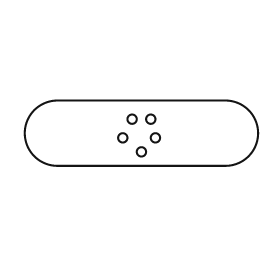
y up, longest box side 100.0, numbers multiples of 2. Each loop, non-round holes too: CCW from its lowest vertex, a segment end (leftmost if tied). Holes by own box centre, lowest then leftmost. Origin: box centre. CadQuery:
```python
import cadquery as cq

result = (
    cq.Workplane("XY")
    .moveTo(-36.0, -14.0)
    .lineTo(36.0, -14.0)
    .threePointArc((50.0, 0.0), (36.0, 14.0))
    .lineTo(-36.0, 14.0)
    .threePointArc((-50.0, 0.0), (-36.0, -14.0))
    .close()
    .moveTo(0.0, -8.0)
    .circle(2.0)
    .moveTo(-8.0, -2.0)
    .circle(2.0)
    .moveTo(6.0, -2.0)
    .circle(2.0)
    .moveTo(-4.0, 6.0)
    .circle(2.0)
    .moveTo(4.0, 6.0)
    .circle(2.0)
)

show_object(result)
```